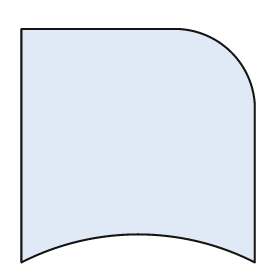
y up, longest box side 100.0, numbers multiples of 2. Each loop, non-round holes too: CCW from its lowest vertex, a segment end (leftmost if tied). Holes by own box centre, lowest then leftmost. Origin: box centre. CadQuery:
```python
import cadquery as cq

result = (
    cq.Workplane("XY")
    .moveTo(-50.0, -50.0)
    .threePointArc((0.0, -38.0), (50.0, -50.0))
    .lineTo(50.0, 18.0)
    .threePointArc((40.0, 40.0), (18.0, 50.0))
    .lineTo(-50.0, 50.0)
    .close()
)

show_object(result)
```